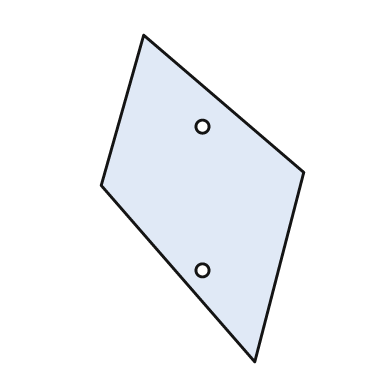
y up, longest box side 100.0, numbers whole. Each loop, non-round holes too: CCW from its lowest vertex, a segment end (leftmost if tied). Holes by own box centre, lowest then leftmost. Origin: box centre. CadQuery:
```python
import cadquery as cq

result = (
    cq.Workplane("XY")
    .moveTo(16.0, -50.0)
    .lineTo(31.0, 8.0)
    .lineTo(-18.0, 50.0)
    .lineTo(-31.0, 4.0)
    .close()
    .moveTo(0.0, -22.0)
    .circle(2.0)
    .moveTo(0.0, 22.0)
    .circle(2.0)
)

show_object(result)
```